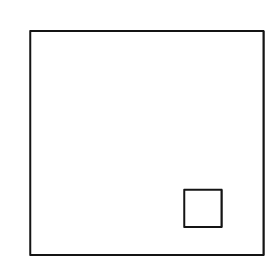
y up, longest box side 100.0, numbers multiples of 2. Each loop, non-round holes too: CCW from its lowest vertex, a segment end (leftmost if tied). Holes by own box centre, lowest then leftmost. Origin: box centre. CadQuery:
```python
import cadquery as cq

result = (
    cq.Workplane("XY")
    .moveTo(-50.0, -48.0)
    .lineTo(50.0, -48.0)
    .lineTo(50.0, 48.0)
    .lineTo(-50.0, 48.0)
    .close()
    .moveTo(16.0, -36.0)
    .lineTo(32.0, -36.0)
    .lineTo(32.0, -20.0)
    .lineTo(16.0, -20.0)
    .close()
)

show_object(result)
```